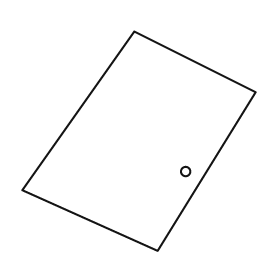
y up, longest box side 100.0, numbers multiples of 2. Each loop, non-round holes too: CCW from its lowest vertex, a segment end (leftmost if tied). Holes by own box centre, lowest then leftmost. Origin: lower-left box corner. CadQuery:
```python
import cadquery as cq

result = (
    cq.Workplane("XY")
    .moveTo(58.0, 0.0)
    .lineTo(100.0, 68.0)
    .lineTo(48.0, 94.0)
    .lineTo(0.0, 26.0)
    .close()
    .moveTo(70.0, 34.0)
    .circle(2.0)
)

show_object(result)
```